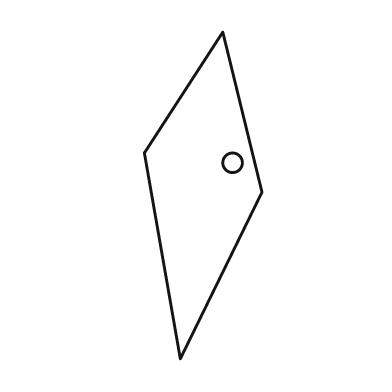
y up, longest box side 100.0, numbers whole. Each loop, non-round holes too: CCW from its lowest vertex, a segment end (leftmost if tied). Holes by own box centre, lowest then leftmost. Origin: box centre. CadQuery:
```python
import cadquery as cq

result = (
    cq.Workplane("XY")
    .moveTo(-7.0, -50.0)
    .lineTo(18.0, 1.0)
    .lineTo(6.0, 50.0)
    .lineTo(-18.0, 13.0)
    .close()
    .moveTo(9.0, 10.0)
    .circle(3.0)
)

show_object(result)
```